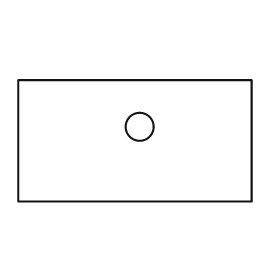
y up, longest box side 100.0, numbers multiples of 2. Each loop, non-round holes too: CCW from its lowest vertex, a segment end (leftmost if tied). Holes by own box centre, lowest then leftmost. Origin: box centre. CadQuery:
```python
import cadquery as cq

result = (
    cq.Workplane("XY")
    .moveTo(-50.0, -26.0)
    .lineTo(50.0, -26.0)
    .lineTo(50.0, 26.0)
    .lineTo(-50.0, 26.0)
    .close()
    .moveTo(2.0, 6.0)
    .circle(6.0)
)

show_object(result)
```